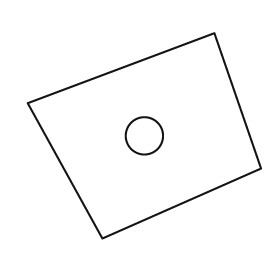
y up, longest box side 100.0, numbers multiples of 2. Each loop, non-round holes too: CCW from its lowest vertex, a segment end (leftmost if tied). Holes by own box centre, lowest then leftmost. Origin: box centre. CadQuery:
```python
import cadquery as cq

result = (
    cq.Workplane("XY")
    .moveTo(-18.0, -44.0)
    .lineTo(50.0, -14.0)
    .lineTo(30.0, 44.0)
    .lineTo(-50.0, 14.0)
    .close()
    .moveTo(0.0, 0.0)
    .circle(8.0)
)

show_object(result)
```